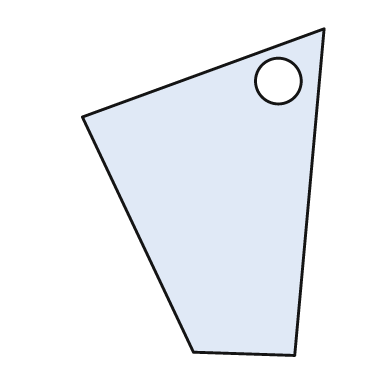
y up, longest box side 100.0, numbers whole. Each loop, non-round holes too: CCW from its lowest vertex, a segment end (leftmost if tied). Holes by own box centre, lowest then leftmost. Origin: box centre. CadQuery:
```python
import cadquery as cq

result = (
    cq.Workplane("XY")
    .moveTo(28.0, -50.0)
    .lineTo(37.0, 50.0)
    .lineTo(-37.0, 23.0)
    .lineTo(-3.0, -49.0)
    .close()
    .moveTo(23.0, 34.0)
    .circle(7.0)
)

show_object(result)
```